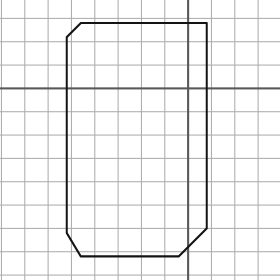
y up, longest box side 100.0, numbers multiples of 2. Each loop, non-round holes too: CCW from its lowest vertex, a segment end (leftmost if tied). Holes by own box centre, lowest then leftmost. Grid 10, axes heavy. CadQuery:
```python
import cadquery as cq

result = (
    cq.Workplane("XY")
    .moveTo(-46.0, -72.0)
    .lineTo(-4.0, -72.0)
    .lineTo(8.0, -60.0)
    .lineTo(8.0, 28.0)
    .lineTo(-46.0, 28.0)
    .lineTo(-52.0, 22.0)
    .lineTo(-52.0, -62.0)
    .close()
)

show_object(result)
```